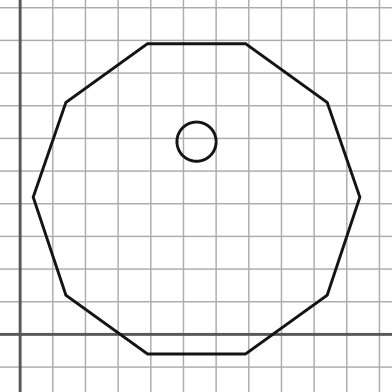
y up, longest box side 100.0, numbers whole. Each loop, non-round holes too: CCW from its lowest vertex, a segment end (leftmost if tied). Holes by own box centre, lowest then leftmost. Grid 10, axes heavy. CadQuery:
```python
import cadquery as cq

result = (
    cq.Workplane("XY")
    .moveTo(39.0, -6.0)
    .lineTo(69.0, -6.0)
    .lineTo(94.0, 12.0)
    .lineTo(104.0, 42.0)
    .lineTo(94.0, 71.0)
    .lineTo(69.0, 89.0)
    .lineTo(39.0, 89.0)
    .lineTo(14.0, 71.0)
    .lineTo(4.0, 42.0)
    .lineTo(14.0, 12.0)
    .close()
    .moveTo(54.0, 59.0)
    .circle(6.0)
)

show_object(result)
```